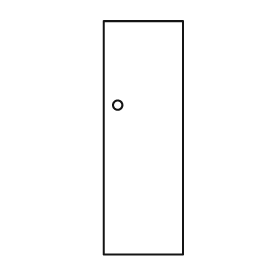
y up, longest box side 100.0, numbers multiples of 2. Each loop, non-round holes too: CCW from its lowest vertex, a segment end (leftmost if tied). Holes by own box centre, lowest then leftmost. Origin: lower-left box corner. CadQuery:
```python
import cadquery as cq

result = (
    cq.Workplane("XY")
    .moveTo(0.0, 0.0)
    .lineTo(34.0, 0.0)
    .lineTo(34.0, 100.0)
    .lineTo(0.0, 100.0)
    .close()
    .moveTo(6.0, 64.0)
    .circle(2.0)
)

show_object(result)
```